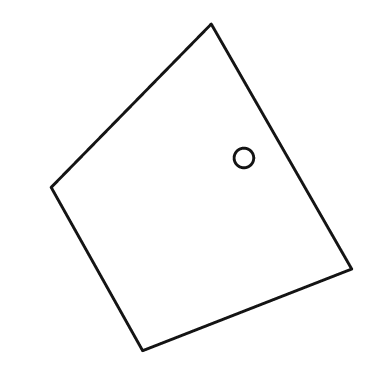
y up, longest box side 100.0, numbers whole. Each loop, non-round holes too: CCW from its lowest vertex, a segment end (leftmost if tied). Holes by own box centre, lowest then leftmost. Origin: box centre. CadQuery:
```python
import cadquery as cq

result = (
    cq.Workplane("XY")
    .moveTo(-18.0, -50.0)
    .lineTo(46.0, -25.0)
    .lineTo(3.0, 50.0)
    .lineTo(-46.0, 0.0)
    .close()
    .moveTo(13.0, 9.0)
    .circle(3.0)
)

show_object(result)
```